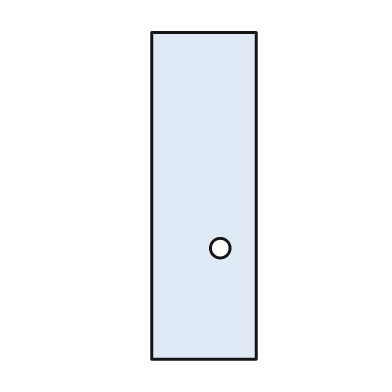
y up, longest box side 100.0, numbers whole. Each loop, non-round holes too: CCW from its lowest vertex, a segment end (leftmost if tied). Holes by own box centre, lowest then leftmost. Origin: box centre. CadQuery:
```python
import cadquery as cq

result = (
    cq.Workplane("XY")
    .moveTo(-16.0, -50.0)
    .lineTo(16.0, -50.0)
    .lineTo(16.0, 50.0)
    .lineTo(-16.0, 50.0)
    .close()
    .moveTo(5.0, -16.0)
    .circle(3.0)
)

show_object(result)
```